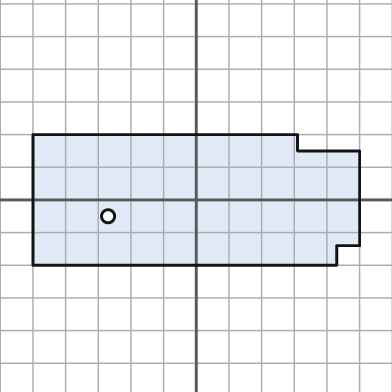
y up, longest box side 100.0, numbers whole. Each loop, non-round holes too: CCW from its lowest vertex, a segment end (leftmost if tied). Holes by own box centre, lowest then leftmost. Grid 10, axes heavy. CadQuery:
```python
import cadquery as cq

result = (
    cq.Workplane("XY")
    .moveTo(-50.0, -20.0)
    .lineTo(43.0, -20.0)
    .lineTo(43.0, -14.0)
    .lineTo(50.0, -14.0)
    .lineTo(50.0, 15.0)
    .lineTo(31.0, 15.0)
    .lineTo(31.0, 20.0)
    .lineTo(-50.0, 20.0)
    .close()
    .moveTo(-27.0, -5.0)
    .circle(2.0)
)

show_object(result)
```